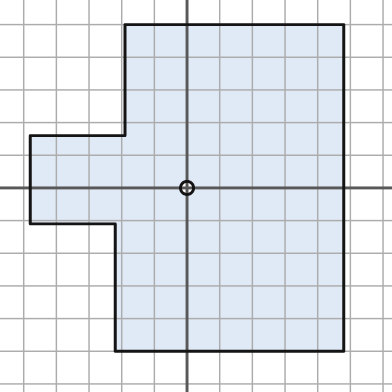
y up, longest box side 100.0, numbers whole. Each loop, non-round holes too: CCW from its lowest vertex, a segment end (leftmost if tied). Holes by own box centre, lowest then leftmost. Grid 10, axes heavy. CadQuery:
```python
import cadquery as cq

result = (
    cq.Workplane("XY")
    .moveTo(-22.0, -50.0)
    .lineTo(48.0, -50.0)
    .lineTo(48.0, 50.0)
    .lineTo(-19.0, 50.0)
    .lineTo(-19.0, 16.0)
    .lineTo(-48.0, 16.0)
    .lineTo(-48.0, -11.0)
    .lineTo(-22.0, -11.0)
    .close()
    .moveTo(0.0, 0.0)
    .circle(2.0)
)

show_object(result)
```